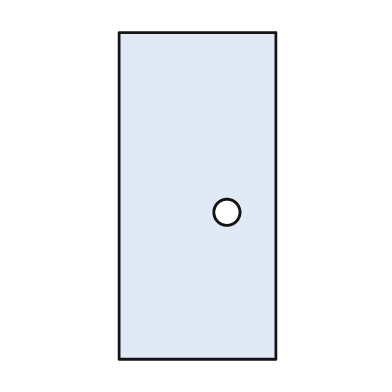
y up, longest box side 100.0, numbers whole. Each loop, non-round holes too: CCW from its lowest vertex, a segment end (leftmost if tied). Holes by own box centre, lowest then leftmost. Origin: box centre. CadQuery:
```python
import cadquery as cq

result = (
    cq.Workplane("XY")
    .moveTo(-24.0, -50.0)
    .lineTo(24.0, -50.0)
    .lineTo(24.0, 50.0)
    .lineTo(-24.0, 50.0)
    .close()
    .moveTo(9.0, -5.0)
    .circle(4.0)
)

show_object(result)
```